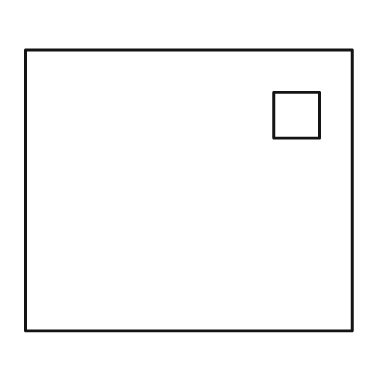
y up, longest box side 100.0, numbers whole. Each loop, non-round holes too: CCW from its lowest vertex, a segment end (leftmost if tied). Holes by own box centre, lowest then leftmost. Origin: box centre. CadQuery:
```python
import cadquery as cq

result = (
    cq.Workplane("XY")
    .moveTo(-50.0, -43.0)
    .lineTo(50.0, -43.0)
    .lineTo(50.0, 43.0)
    .lineTo(-50.0, 43.0)
    .close()
    .moveTo(26.0, 16.0)
    .lineTo(40.0, 16.0)
    .lineTo(40.0, 30.0)
    .lineTo(26.0, 30.0)
    .close()
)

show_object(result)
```